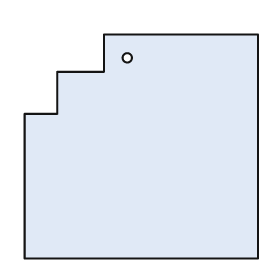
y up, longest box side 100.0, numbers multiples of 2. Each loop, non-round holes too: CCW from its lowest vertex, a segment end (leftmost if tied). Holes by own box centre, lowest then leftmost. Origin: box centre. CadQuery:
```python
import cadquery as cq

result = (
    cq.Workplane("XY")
    .moveTo(-50.0, -48.0)
    .lineTo(50.0, -48.0)
    .lineTo(50.0, 48.0)
    .lineTo(-16.0, 48.0)
    .lineTo(-16.0, 32.0)
    .lineTo(-36.0, 32.0)
    .lineTo(-36.0, 14.0)
    .lineTo(-50.0, 14.0)
    .close()
    .moveTo(-6.0, 38.0)
    .circle(2.0)
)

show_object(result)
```